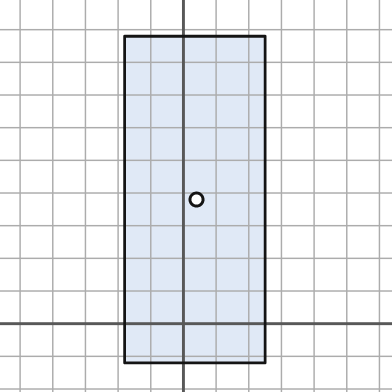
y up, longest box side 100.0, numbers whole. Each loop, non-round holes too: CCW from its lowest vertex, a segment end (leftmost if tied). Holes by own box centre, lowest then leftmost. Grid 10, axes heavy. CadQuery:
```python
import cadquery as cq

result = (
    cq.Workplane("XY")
    .moveTo(-18.0, -12.0)
    .lineTo(25.0, -12.0)
    .lineTo(25.0, 88.0)
    .lineTo(-18.0, 88.0)
    .close()
    .moveTo(4.0, 38.0)
    .circle(2.0)
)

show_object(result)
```